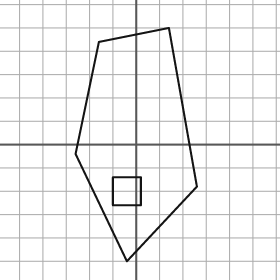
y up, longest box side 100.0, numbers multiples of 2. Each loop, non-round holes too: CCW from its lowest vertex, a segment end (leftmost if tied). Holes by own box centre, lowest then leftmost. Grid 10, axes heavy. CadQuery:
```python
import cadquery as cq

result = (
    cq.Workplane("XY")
    .moveTo(-4.0, -50.0)
    .lineTo(26.0, -18.0)
    .lineTo(14.0, 50.0)
    .lineTo(-16.0, 44.0)
    .lineTo(-26.0, -4.0)
    .close()
    .moveTo(-10.0, -26.0)
    .lineTo(2.0, -26.0)
    .lineTo(2.0, -14.0)
    .lineTo(-10.0, -14.0)
    .close()
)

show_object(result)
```